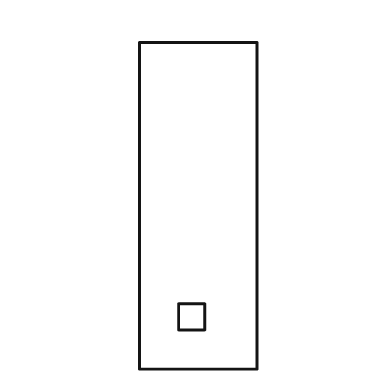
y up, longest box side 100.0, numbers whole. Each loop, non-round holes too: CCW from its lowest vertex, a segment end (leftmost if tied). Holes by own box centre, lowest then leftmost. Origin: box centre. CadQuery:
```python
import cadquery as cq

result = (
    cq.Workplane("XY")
    .moveTo(-18.0, -50.0)
    .lineTo(18.0, -50.0)
    .lineTo(18.0, 50.0)
    .lineTo(-18.0, 50.0)
    .close()
    .moveTo(-6.0, -38.0)
    .lineTo(2.0, -38.0)
    .lineTo(2.0, -30.0)
    .lineTo(-6.0, -30.0)
    .close()
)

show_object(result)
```